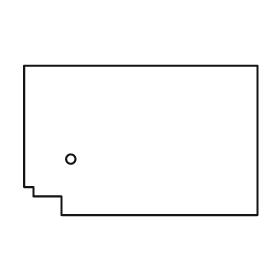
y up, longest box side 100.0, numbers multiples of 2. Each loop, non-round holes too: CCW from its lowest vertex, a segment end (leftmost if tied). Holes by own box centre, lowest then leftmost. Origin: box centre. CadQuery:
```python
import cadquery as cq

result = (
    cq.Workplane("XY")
    .moveTo(-34.0, -32.0)
    .lineTo(50.0, -32.0)
    .lineTo(50.0, 32.0)
    .lineTo(-50.0, 32.0)
    .lineTo(-50.0, -20.0)
    .lineTo(-46.0, -20.0)
    .lineTo(-46.0, -24.0)
    .lineTo(-34.0, -24.0)
    .close()
    .moveTo(-30.0, -8.0)
    .circle(2.0)
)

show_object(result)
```